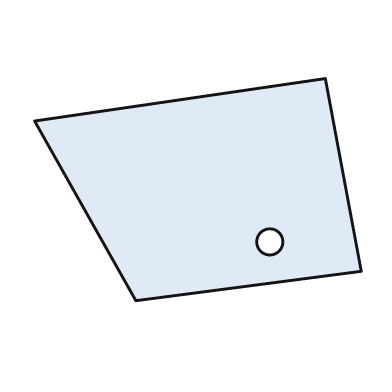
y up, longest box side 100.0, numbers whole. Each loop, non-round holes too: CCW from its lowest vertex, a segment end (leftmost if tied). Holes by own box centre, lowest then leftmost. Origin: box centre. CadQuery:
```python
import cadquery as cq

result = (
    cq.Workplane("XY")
    .moveTo(-19.0, -34.0)
    .lineTo(50.0, -25.0)
    .lineTo(39.0, 34.0)
    .lineTo(-50.0, 21.0)
    .close()
    .moveTo(22.0, -16.0)
    .circle(4.0)
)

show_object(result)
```